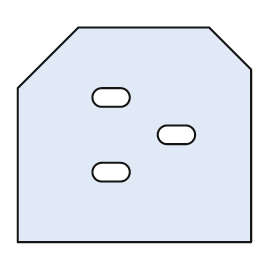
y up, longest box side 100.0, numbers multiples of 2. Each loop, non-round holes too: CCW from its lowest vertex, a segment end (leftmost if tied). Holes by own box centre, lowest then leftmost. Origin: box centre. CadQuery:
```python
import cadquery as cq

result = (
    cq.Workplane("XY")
    .moveTo(-50.0, -46.0)
    .lineTo(50.0, -46.0)
    .lineTo(50.0, 28.0)
    .lineTo(32.0, 46.0)
    .lineTo(-24.0, 46.0)
    .lineTo(-50.0, 20.0)
    .close()
    .moveTo(-14.0, -20.0)
    .lineTo(-6.0, -20.0)
    .threePointArc((-2.0, -16.0), (-6.0, -12.0))
    .lineTo(-14.0, -12.0)
    .threePointArc((-18.0, -16.0), (-14.0, -20.0))
    .close()
    .moveTo(14.0, -4.0)
    .lineTo(22.0, -4.0)
    .threePointArc((26.0, 0.0), (22.0, 4.0))
    .lineTo(14.0, 4.0)
    .threePointArc((10.0, 0.0), (14.0, -4.0))
    .close()
    .moveTo(-14.0, 12.0)
    .lineTo(-6.0, 12.0)
    .threePointArc((-2.0, 16.0), (-6.0, 20.0))
    .lineTo(-14.0, 20.0)
    .threePointArc((-18.0, 16.0), (-14.0, 12.0))
    .close()
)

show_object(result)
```